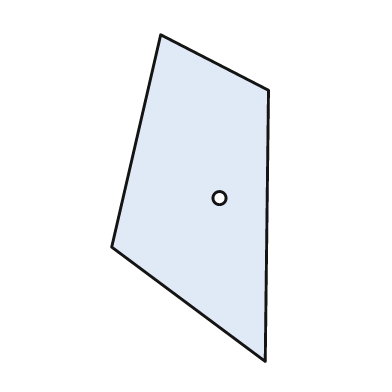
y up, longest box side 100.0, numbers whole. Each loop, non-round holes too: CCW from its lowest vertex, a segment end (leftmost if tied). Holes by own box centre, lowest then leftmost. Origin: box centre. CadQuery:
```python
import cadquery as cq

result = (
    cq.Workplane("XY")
    .moveTo(23.0, -50.0)
    .lineTo(24.0, 33.0)
    .lineTo(-9.0, 50.0)
    .lineTo(-24.0, -15.0)
    .close()
    .moveTo(9.0, 0.0)
    .circle(2.0)
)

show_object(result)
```